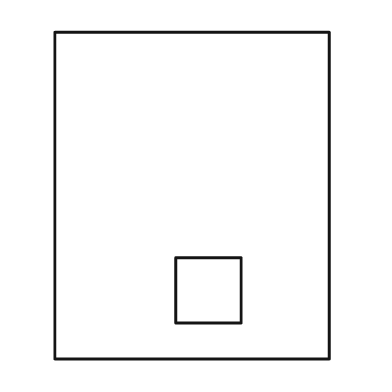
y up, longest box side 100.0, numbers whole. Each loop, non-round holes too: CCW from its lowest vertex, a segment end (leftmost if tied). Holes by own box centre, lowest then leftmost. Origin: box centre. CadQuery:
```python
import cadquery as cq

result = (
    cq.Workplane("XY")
    .moveTo(-42.0, -50.0)
    .lineTo(42.0, -50.0)
    .lineTo(42.0, 50.0)
    .lineTo(-42.0, 50.0)
    .close()
    .moveTo(-5.0, -39.0)
    .lineTo(15.0, -39.0)
    .lineTo(15.0, -19.0)
    .lineTo(-5.0, -19.0)
    .close()
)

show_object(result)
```